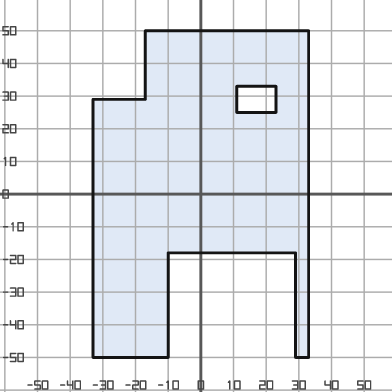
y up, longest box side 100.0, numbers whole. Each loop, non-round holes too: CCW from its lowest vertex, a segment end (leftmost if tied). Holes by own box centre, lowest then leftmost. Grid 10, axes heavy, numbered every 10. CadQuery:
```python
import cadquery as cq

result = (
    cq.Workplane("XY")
    .moveTo(-33.0, -50.0)
    .lineTo(-10.0, -50.0)
    .lineTo(-10.0, -18.0)
    .lineTo(29.0, -18.0)
    .lineTo(29.0, -50.0)
    .lineTo(33.0, -50.0)
    .lineTo(33.0, 50.0)
    .lineTo(-17.0, 50.0)
    .lineTo(-17.0, 29.0)
    .lineTo(-33.0, 29.0)
    .close()
    .moveTo(11.0, 25.0)
    .lineTo(23.0, 25.0)
    .lineTo(23.0, 33.0)
    .lineTo(11.0, 33.0)
    .close()
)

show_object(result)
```